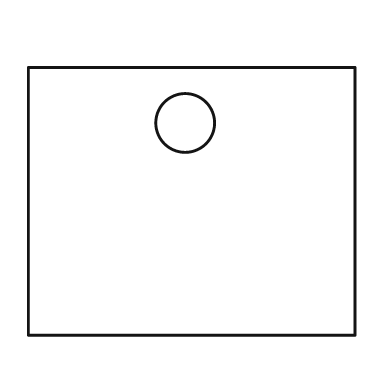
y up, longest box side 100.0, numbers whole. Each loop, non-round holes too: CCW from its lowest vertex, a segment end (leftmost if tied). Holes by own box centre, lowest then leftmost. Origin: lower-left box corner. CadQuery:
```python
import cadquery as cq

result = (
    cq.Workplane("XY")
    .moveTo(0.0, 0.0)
    .lineTo(100.0, 0.0)
    .lineTo(100.0, 82.0)
    .lineTo(0.0, 82.0)
    .close()
    .moveTo(48.0, 65.0)
    .circle(9.0)
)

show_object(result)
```